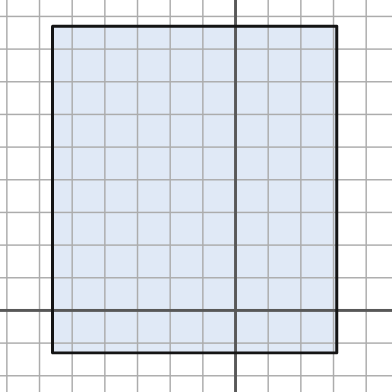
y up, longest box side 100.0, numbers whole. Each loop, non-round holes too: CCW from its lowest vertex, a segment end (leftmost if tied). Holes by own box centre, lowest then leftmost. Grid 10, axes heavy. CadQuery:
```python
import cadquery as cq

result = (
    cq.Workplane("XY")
    .moveTo(-56.0, -13.0)
    .lineTo(31.0, -13.0)
    .lineTo(31.0, 87.0)
    .lineTo(-56.0, 87.0)
    .close()
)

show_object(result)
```